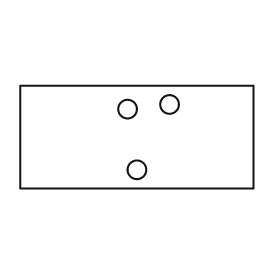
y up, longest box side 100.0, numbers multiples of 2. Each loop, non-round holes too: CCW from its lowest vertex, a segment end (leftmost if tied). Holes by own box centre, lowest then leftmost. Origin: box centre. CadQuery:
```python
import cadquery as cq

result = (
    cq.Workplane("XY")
    .moveTo(-50.0, -22.0)
    .lineTo(50.0, -22.0)
    .lineTo(50.0, 22.0)
    .lineTo(-50.0, 22.0)
    .close()
    .moveTo(0.0, -14.0)
    .circle(4.0)
    .moveTo(-4.0, 12.0)
    .circle(4.0)
    .moveTo(14.0, 14.0)
    .circle(4.0)
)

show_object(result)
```